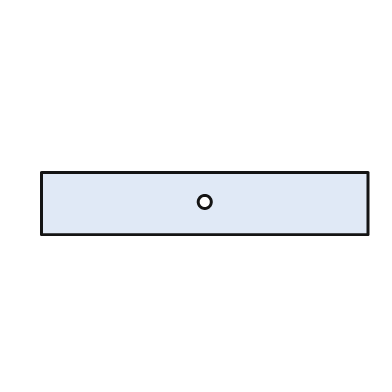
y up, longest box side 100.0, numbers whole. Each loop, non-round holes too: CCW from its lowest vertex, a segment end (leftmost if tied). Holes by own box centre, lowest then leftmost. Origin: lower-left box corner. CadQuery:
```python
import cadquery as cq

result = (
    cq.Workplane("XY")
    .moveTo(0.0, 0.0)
    .lineTo(100.0, 0.0)
    .lineTo(100.0, 19.0)
    .lineTo(0.0, 19.0)
    .close()
    .moveTo(50.0, 10.0)
    .circle(2.0)
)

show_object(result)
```